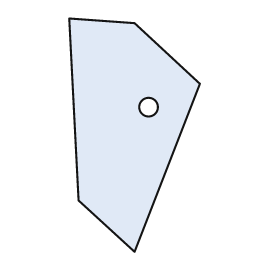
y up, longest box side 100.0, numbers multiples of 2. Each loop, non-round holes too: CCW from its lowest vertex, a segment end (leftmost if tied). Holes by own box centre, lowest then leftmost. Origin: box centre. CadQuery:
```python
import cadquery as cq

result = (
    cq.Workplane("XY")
    .moveTo(0.0, -50.0)
    .lineTo(28.0, 22.0)
    .lineTo(0.0, 48.0)
    .lineTo(-28.0, 50.0)
    .lineTo(-24.0, -28.0)
    .close()
    .moveTo(6.0, 12.0)
    .circle(4.0)
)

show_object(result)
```